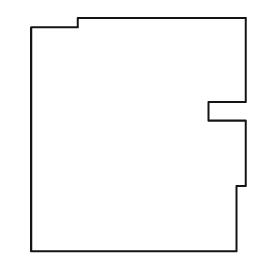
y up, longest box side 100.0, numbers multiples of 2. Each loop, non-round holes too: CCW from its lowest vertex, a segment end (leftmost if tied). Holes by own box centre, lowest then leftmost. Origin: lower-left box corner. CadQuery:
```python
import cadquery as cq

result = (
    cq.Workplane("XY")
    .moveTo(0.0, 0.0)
    .lineTo(88.0, 0.0)
    .lineTo(88.0, 28.0)
    .lineTo(92.0, 28.0)
    .lineTo(92.0, 56.0)
    .lineTo(76.0, 56.0)
    .lineTo(76.0, 64.0)
    .lineTo(92.0, 64.0)
    .lineTo(92.0, 100.0)
    .lineTo(20.0, 100.0)
    .lineTo(20.0, 96.0)
    .lineTo(0.0, 96.0)
    .close()
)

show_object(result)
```